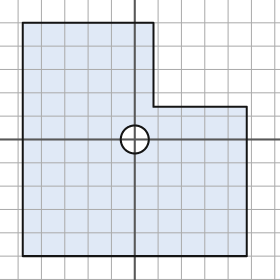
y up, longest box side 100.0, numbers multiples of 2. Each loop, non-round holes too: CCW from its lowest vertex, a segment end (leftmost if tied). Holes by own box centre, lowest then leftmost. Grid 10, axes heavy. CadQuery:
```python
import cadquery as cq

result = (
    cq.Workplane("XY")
    .moveTo(-48.0, -50.0)
    .lineTo(48.0, -50.0)
    .lineTo(48.0, 14.0)
    .lineTo(8.0, 14.0)
    .lineTo(8.0, 50.0)
    .lineTo(-48.0, 50.0)
    .close()
    .moveTo(0.0, 0.0)
    .circle(6.0)
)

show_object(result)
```